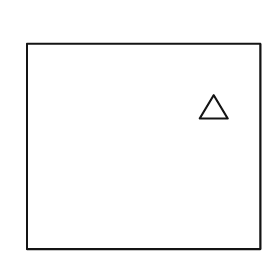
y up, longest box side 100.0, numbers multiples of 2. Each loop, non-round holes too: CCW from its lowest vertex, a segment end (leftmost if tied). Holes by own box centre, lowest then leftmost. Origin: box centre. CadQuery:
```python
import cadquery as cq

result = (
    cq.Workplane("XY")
    .moveTo(-50.0, -44.0)
    .lineTo(50.0, -44.0)
    .lineTo(50.0, 44.0)
    .lineTo(-50.0, 44.0)
    .close()
    .moveTo(24.0, 12.0)
    .lineTo(36.0, 12.0)
    .lineTo(30.0, 22.0)
    .close()
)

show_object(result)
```